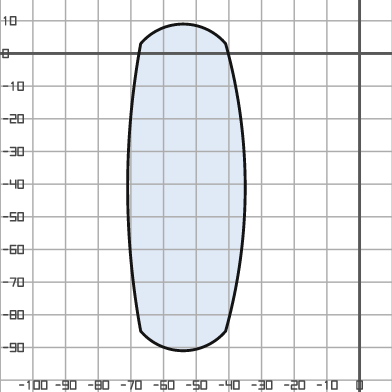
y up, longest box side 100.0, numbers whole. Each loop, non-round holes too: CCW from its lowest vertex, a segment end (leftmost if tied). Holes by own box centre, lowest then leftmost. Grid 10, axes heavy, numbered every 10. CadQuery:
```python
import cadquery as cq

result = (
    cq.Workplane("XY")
    .moveTo(-67.0, -85.0)
    .threePointArc((-54.0, -91.0), (-41.0, -85.0))
    .threePointArc((-35.0, -41.0), (-41.0, 3.0))
    .threePointArc((-54.0, 9.0), (-67.0, 3.0))
    .threePointArc((-71.0, -41.0), (-67.0, -85.0))
    .close()
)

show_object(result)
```